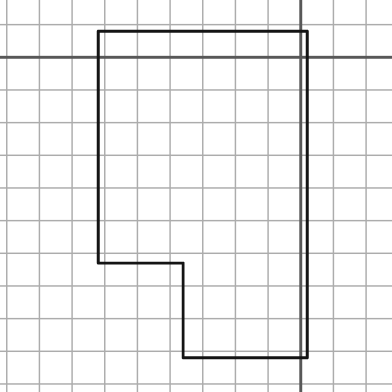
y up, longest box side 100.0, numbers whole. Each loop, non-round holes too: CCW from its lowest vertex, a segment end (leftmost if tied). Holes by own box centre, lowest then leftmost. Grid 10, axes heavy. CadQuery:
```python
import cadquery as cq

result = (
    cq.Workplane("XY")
    .moveTo(-36.0, -92.0)
    .lineTo(2.0, -92.0)
    .lineTo(2.0, 8.0)
    .lineTo(-62.0, 8.0)
    .lineTo(-62.0, -63.0)
    .lineTo(-36.0, -63.0)
    .close()
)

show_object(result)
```